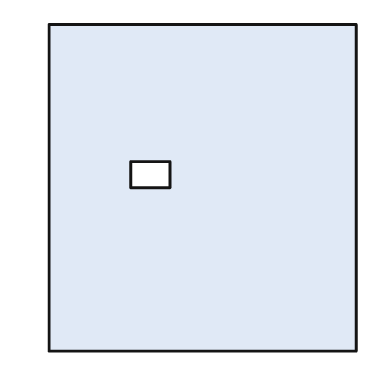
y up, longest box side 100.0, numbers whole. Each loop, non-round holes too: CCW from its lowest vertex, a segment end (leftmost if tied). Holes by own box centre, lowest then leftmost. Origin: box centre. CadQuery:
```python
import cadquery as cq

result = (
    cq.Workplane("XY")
    .moveTo(-47.0, -50.0)
    .lineTo(47.0, -50.0)
    .lineTo(47.0, 50.0)
    .lineTo(-47.0, 50.0)
    .close()
    .moveTo(-22.0, 0.0)
    .lineTo(-10.0, 0.0)
    .lineTo(-10.0, 8.0)
    .lineTo(-22.0, 8.0)
    .close()
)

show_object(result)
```